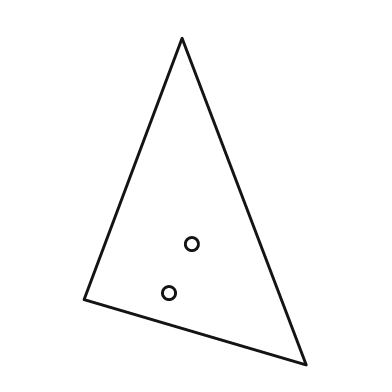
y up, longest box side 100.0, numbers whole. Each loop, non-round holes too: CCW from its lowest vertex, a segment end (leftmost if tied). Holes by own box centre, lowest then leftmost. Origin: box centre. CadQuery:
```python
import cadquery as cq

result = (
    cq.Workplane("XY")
    .moveTo(34.0, -50.0)
    .lineTo(-4.0, 50.0)
    .lineTo(-34.0, -30.0)
    .close()
    .moveTo(-8.0, -28.0)
    .circle(2.0)
    .moveTo(-1.0, -13.0)
    .circle(2.0)
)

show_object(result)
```